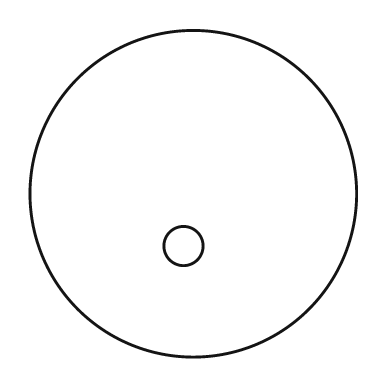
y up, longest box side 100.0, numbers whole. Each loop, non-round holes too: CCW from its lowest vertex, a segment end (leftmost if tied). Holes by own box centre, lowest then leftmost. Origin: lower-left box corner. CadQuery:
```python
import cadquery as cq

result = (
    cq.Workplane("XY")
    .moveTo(50.0, 50.0)
    .circle(50.0)
    .moveTo(47.0, 34.0)
    .circle(6.0)
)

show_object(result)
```